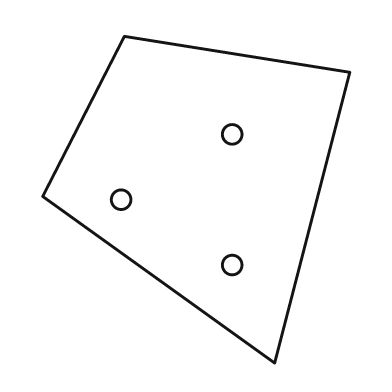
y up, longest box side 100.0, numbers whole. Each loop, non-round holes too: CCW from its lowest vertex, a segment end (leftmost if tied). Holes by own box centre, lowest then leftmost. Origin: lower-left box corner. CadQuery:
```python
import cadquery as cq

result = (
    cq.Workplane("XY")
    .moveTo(71.0, 0.0)
    .lineTo(94.0, 89.0)
    .lineTo(25.0, 100.0)
    .lineTo(0.0, 51.0)
    .close()
    .moveTo(58.0, 30.0)
    .circle(3.0)
    .moveTo(24.0, 50.0)
    .circle(3.0)
    .moveTo(58.0, 70.0)
    .circle(3.0)
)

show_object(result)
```